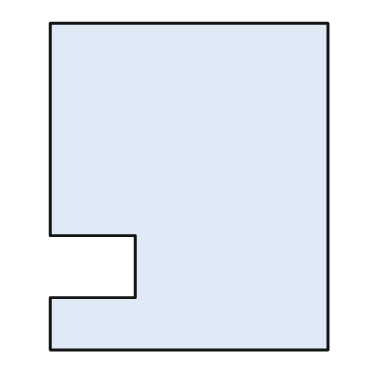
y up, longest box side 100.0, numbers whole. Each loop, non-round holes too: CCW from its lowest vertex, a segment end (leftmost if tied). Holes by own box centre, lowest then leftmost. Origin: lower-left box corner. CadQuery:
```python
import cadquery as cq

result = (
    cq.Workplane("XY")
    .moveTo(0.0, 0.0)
    .lineTo(85.0, 0.0)
    .lineTo(85.0, 100.0)
    .lineTo(0.0, 100.0)
    .lineTo(0.0, 35.0)
    .lineTo(26.0, 35.0)
    .lineTo(26.0, 16.0)
    .lineTo(0.0, 16.0)
    .close()
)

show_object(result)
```